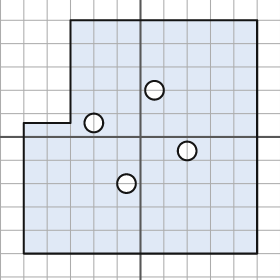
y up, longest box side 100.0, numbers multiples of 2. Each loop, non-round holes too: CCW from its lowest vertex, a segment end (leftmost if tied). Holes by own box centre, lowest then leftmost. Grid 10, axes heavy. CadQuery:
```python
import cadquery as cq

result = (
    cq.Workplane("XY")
    .moveTo(-50.0, -50.0)
    .lineTo(50.0, -50.0)
    .lineTo(50.0, 50.0)
    .lineTo(-30.0, 50.0)
    .lineTo(-30.0, 6.0)
    .lineTo(-50.0, 6.0)
    .close()
    .moveTo(-6.0, -20.0)
    .circle(4.0)
    .moveTo(20.0, -6.0)
    .circle(4.0)
    .moveTo(-20.0, 6.0)
    .circle(4.0)
    .moveTo(6.0, 20.0)
    .circle(4.0)
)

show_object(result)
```